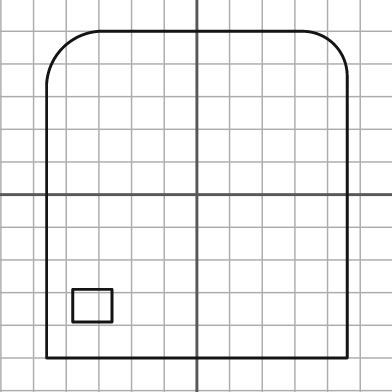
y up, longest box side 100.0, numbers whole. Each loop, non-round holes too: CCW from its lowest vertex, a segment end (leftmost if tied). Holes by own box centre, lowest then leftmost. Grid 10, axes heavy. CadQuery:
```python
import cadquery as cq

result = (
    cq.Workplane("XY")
    .moveTo(-46.0, -50.0)
    .lineTo(46.0, -50.0)
    .lineTo(46.0, 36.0)
    .threePointArc((42.0, 46.0), (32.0, 50.0))
    .lineTo(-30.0, 50.0)
    .threePointArc((-41.0, 45.0), (-46.0, 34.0))
    .close()
    .moveTo(-38.0, -39.0)
    .lineTo(-26.0, -39.0)
    .lineTo(-26.0, -29.0)
    .lineTo(-38.0, -29.0)
    .close()
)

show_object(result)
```